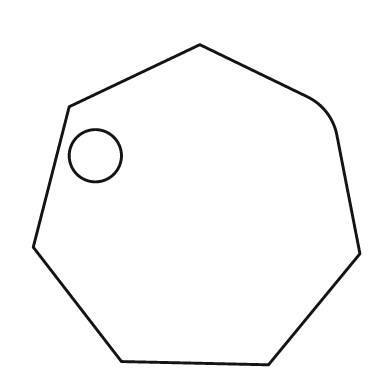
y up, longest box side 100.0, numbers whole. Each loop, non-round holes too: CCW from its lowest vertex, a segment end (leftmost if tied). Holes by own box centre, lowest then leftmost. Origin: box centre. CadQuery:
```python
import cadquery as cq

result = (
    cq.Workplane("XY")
    .moveTo(22.0, -49.0)
    .lineTo(50.0, -15.0)
    .lineTo(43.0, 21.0)
    .threePointArc((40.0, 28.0), (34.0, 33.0))
    .lineTo(1.0, 49.0)
    .lineTo(-39.0, 30.0)
    .lineTo(-50.0, -13.0)
    .lineTo(-23.0, -48.0)
    .close()
    .moveTo(-31.0, 15.0)
    .circle(8.0)
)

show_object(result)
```